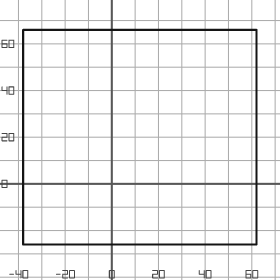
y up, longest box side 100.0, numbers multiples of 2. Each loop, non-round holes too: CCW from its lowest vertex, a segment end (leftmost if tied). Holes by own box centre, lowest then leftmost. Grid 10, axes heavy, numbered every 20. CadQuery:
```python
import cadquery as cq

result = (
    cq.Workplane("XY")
    .moveTo(-38.0, -26.0)
    .lineTo(62.0, -26.0)
    .lineTo(62.0, 66.0)
    .lineTo(-38.0, 66.0)
    .close()
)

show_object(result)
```